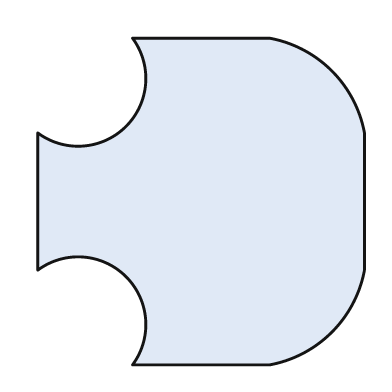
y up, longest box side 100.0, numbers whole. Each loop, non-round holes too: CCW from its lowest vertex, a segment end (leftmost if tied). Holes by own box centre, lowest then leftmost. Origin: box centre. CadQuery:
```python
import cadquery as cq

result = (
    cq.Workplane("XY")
    .moveTo(-21.0, -50.0)
    .lineTo(21.0, -50.0)
    .threePointArc((40.0, -40.0), (50.0, -21.0))
    .lineTo(50.0, 21.0)
    .threePointArc((40.0, 40.0), (21.0, 50.0))
    .lineTo(-21.0, 50.0)
    .threePointArc((-23.0, 23.0), (-50.0, 21.0))
    .lineTo(-50.0, -21.0)
    .threePointArc((-23.0, -23.0), (-21.0, -50.0))
    .close()
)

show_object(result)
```